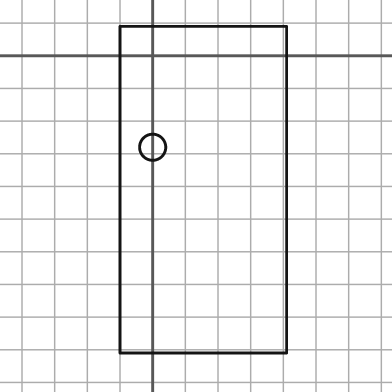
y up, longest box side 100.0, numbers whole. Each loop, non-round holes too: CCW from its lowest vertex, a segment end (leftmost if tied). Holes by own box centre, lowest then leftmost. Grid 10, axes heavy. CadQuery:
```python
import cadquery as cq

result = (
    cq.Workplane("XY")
    .moveTo(-10.0, -91.0)
    .lineTo(41.0, -91.0)
    .lineTo(41.0, 9.0)
    .lineTo(-10.0, 9.0)
    .close()
    .moveTo(0.0, -28.0)
    .circle(4.0)
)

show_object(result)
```